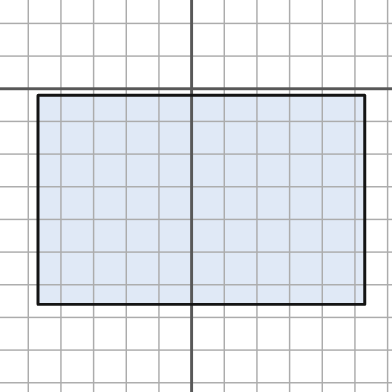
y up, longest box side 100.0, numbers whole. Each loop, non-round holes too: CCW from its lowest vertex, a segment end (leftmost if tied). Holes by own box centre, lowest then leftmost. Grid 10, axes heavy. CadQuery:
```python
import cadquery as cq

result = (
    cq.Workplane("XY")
    .moveTo(-47.0, -66.0)
    .lineTo(53.0, -66.0)
    .lineTo(53.0, -2.0)
    .lineTo(-47.0, -2.0)
    .close()
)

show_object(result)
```